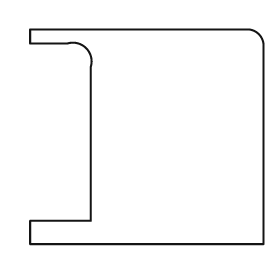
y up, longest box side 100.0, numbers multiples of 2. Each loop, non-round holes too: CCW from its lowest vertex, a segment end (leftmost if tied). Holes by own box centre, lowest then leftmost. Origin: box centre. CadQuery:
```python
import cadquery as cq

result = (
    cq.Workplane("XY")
    .moveTo(-50.0, -46.0)
    .lineTo(50.0, -46.0)
    .lineTo(50.0, 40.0)
    .threePointArc((48.0, 44.0), (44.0, 46.0))
    .lineTo(-50.0, 46.0)
    .lineTo(-50.0, 40.0)
    .lineTo(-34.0, 40.0)
    .threePointArc((-26.0, 38.0), (-24.0, 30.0))
    .lineTo(-24.0, -36.0)
    .lineTo(-50.0, -36.0)
    .close()
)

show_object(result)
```